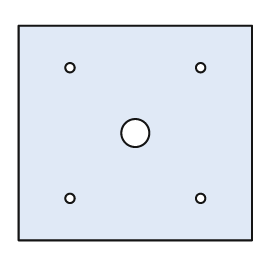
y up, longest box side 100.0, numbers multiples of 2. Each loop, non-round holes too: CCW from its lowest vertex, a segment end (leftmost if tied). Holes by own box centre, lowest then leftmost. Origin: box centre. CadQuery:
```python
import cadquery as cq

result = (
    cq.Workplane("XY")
    .moveTo(-50.0, -46.0)
    .lineTo(50.0, -46.0)
    .lineTo(50.0, 46.0)
    .lineTo(-50.0, 46.0)
    .close()
    .moveTo(-28.0, -28.0)
    .circle(2.0)
    .moveTo(28.0, -28.0)
    .circle(2.0)
    .moveTo(0.0, 0.0)
    .circle(6.0)
    .moveTo(-28.0, 28.0)
    .circle(2.0)
    .moveTo(28.0, 28.0)
    .circle(2.0)
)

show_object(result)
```